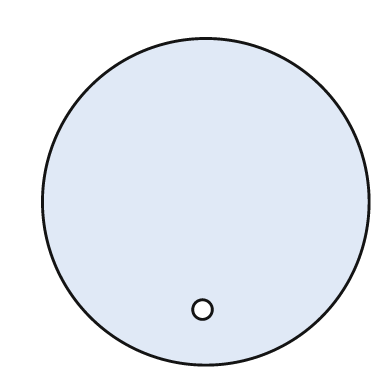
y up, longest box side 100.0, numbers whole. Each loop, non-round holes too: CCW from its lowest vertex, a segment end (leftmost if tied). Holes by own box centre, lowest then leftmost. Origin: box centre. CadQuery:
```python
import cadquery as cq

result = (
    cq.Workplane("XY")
    .moveTo(0.0, 0.0)
    .circle(50.0)
    .moveTo(-1.0, -33.0)
    .circle(3.0)
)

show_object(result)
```